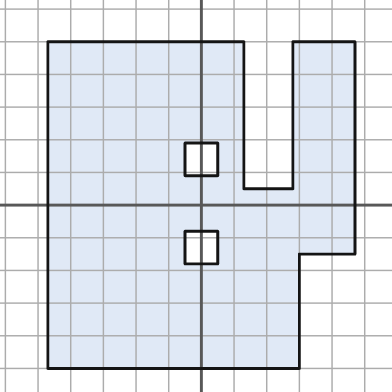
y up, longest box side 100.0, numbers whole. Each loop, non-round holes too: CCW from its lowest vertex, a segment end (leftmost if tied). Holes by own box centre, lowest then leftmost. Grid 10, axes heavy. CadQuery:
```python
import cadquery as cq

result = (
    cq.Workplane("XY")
    .moveTo(-47.0, -50.0)
    .lineTo(30.0, -50.0)
    .lineTo(30.0, -15.0)
    .lineTo(47.0, -15.0)
    .lineTo(47.0, 50.0)
    .lineTo(28.0, 50.0)
    .lineTo(28.0, 5.0)
    .lineTo(13.0, 5.0)
    .lineTo(13.0, 50.0)
    .lineTo(-47.0, 50.0)
    .close()
    .moveTo(-5.0, -18.0)
    .lineTo(5.0, -18.0)
    .lineTo(5.0, -8.0)
    .lineTo(-5.0, -8.0)
    .close()
    .moveTo(-5.0, 9.0)
    .lineTo(5.0, 9.0)
    .lineTo(5.0, 19.0)
    .lineTo(-5.0, 19.0)
    .close()
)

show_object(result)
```